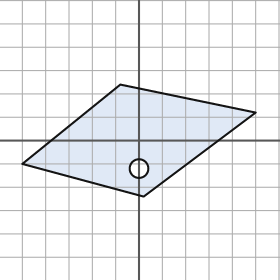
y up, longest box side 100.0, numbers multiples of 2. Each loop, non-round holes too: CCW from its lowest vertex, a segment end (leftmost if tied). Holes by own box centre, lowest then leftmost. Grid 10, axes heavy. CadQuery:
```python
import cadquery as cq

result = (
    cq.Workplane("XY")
    .moveTo(2.0, -24.0)
    .lineTo(50.0, 12.0)
    .lineTo(-8.0, 24.0)
    .lineTo(-50.0, -10.0)
    .close()
    .moveTo(0.0, -12.0)
    .circle(4.0)
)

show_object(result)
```